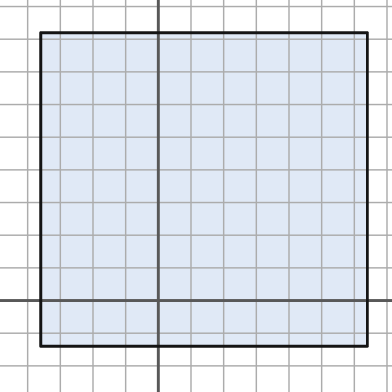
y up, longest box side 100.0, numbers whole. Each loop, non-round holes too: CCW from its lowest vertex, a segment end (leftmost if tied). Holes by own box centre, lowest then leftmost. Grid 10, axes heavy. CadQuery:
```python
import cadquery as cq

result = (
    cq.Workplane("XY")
    .moveTo(-36.0, -14.0)
    .lineTo(64.0, -14.0)
    .lineTo(64.0, 82.0)
    .lineTo(-36.0, 82.0)
    .close()
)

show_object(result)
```